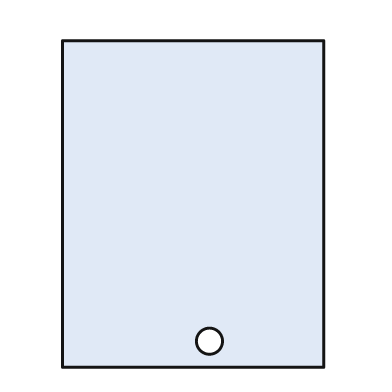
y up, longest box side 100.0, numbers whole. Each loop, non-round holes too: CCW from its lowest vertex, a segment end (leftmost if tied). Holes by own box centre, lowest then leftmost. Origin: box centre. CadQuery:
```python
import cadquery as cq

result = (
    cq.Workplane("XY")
    .moveTo(-40.0, -50.0)
    .lineTo(40.0, -50.0)
    .lineTo(40.0, 50.0)
    .lineTo(-40.0, 50.0)
    .close()
    .moveTo(5.0, -42.0)
    .circle(4.0)
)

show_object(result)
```